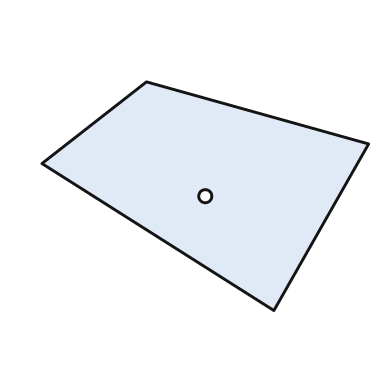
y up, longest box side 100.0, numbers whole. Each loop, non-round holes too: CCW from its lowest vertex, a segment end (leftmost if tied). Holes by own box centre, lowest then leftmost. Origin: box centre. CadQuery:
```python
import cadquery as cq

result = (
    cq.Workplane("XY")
    .moveTo(21.0, -35.0)
    .lineTo(50.0, 16.0)
    .lineTo(-18.0, 35.0)
    .lineTo(-50.0, 10.0)
    .close()
    .moveTo(0.0, 0.0)
    .circle(2.0)
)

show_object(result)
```